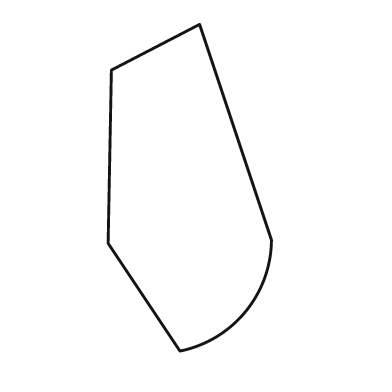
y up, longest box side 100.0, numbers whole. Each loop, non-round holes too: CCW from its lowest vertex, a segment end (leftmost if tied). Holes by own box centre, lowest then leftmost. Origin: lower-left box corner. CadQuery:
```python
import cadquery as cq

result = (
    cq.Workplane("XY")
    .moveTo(22.0, 0.0)
    .threePointArc((42.0, 12.0), (50.0, 34.0))
    .lineTo(28.0, 100.0)
    .lineTo(1.0, 86.0)
    .lineTo(0.0, 33.0)
    .close()
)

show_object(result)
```